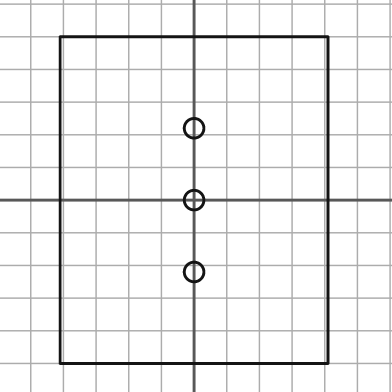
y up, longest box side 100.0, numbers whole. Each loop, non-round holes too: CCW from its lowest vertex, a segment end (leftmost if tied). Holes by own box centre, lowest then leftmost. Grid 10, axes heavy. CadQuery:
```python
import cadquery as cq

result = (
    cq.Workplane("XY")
    .moveTo(-41.0, -50.0)
    .lineTo(41.0, -50.0)
    .lineTo(41.0, 50.0)
    .lineTo(-41.0, 50.0)
    .close()
    .moveTo(0.0, -22.0)
    .circle(3.0)
    .moveTo(0.0, 0.0)
    .circle(3.0)
    .moveTo(0.0, 22.0)
    .circle(3.0)
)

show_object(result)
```